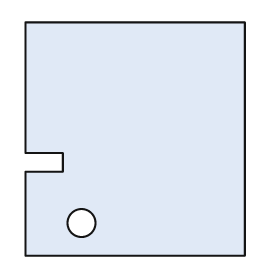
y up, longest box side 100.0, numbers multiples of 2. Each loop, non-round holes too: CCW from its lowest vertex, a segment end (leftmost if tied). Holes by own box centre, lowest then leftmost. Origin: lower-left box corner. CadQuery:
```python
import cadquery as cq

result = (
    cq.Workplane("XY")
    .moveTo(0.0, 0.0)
    .lineTo(94.0, 0.0)
    .lineTo(94.0, 100.0)
    .lineTo(0.0, 100.0)
    .lineTo(0.0, 44.0)
    .lineTo(16.0, 44.0)
    .lineTo(16.0, 36.0)
    .lineTo(0.0, 36.0)
    .close()
    .moveTo(24.0, 14.0)
    .circle(6.0)
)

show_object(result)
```